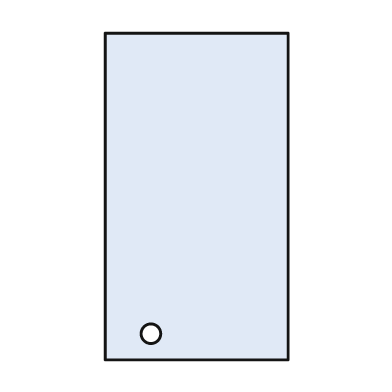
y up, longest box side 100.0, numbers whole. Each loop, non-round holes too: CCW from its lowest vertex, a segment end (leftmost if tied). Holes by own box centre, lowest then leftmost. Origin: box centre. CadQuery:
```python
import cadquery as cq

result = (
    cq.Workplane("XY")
    .moveTo(-28.0, -50.0)
    .lineTo(28.0, -50.0)
    .lineTo(28.0, 50.0)
    .lineTo(-28.0, 50.0)
    .close()
    .moveTo(-14.0, -42.0)
    .circle(3.0)
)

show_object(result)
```